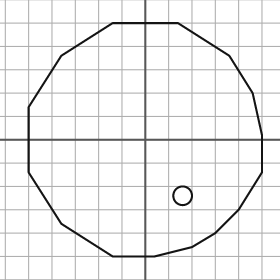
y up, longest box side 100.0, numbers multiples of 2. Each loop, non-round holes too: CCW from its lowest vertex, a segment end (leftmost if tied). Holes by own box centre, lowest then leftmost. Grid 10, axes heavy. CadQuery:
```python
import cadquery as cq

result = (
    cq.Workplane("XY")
    .moveTo(-14.0, -50.0)
    .lineTo(4.0, -50.0)
    .lineTo(20.0, -46.0)
    .lineTo(30.0, -40.0)
    .lineTo(40.0, -30.0)
    .lineTo(50.0, -14.0)
    .lineTo(50.0, 2.0)
    .lineTo(46.0, 20.0)
    .lineTo(36.0, 36.0)
    .lineTo(14.0, 50.0)
    .lineTo(-14.0, 50.0)
    .lineTo(-36.0, 36.0)
    .lineTo(-50.0, 14.0)
    .lineTo(-50.0, -14.0)
    .lineTo(-36.0, -36.0)
    .close()
    .moveTo(16.0, -24.0)
    .circle(4.0)
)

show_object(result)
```